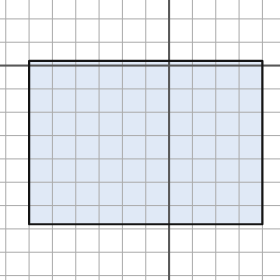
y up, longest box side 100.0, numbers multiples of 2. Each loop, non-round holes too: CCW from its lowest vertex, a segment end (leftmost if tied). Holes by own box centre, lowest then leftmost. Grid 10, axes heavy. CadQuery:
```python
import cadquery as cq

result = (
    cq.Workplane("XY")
    .moveTo(-60.0, -68.0)
    .lineTo(40.0, -68.0)
    .lineTo(40.0, 2.0)
    .lineTo(-60.0, 2.0)
    .close()
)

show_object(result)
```